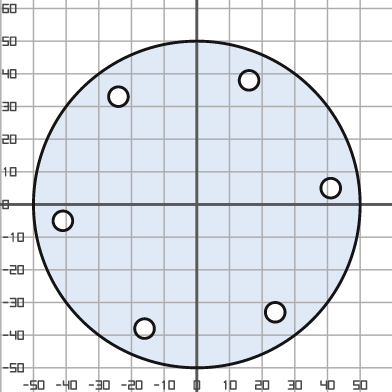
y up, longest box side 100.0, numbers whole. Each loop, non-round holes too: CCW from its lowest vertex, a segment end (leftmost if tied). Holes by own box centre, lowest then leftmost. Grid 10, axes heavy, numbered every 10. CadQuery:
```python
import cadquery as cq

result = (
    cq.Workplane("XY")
    .moveTo(0.0, 0.0)
    .circle(50.0)
    .moveTo(-16.0, -38.0)
    .circle(3.0)
    .moveTo(24.0, -33.0)
    .circle(3.0)
    .moveTo(-41.0, -5.0)
    .circle(3.0)
    .moveTo(41.0, 5.0)
    .circle(3.0)
    .moveTo(-24.0, 33.0)
    .circle(3.0)
    .moveTo(16.0, 38.0)
    .circle(3.0)
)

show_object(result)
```